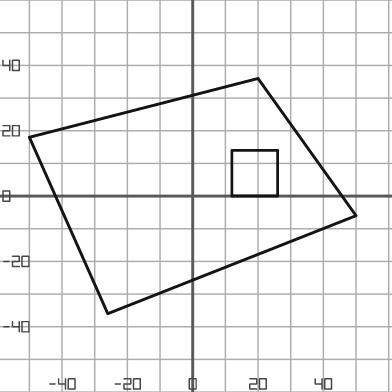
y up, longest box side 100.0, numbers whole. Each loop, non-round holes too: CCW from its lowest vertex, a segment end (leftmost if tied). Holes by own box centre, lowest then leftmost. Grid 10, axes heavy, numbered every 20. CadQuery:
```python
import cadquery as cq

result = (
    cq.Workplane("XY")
    .moveTo(-26.0, -36.0)
    .lineTo(50.0, -6.0)
    .lineTo(20.0, 36.0)
    .lineTo(-50.0, 18.0)
    .close()
    .moveTo(12.0, 0.0)
    .lineTo(26.0, 0.0)
    .lineTo(26.0, 14.0)
    .lineTo(12.0, 14.0)
    .close()
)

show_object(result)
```